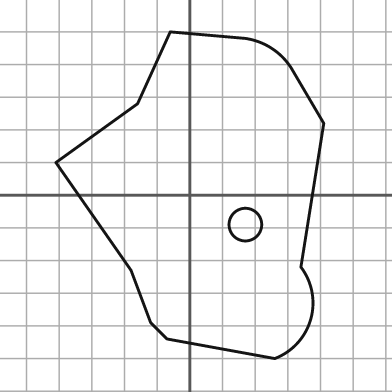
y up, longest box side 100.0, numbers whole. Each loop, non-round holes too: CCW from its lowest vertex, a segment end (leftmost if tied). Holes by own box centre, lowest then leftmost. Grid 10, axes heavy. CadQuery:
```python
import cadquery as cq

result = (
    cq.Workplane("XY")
    .moveTo(26.0, -50.0)
    .threePointArc((37.0, -38.0), (34.0, -22.0))
    .lineTo(41.0, 22.0)
    .lineTo(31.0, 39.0)
    .threePointArc((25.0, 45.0), (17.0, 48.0))
    .lineTo(-6.0, 50.0)
    .lineTo(-16.0, 28.0)
    .lineTo(-41.0, 10.0)
    .lineTo(-18.0, -23.0)
    .lineTo(-12.0, -39.0)
    .lineTo(-7.0, -44.0)
    .close()
    .moveTo(17.0, -9.0)
    .circle(5.0)
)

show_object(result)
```